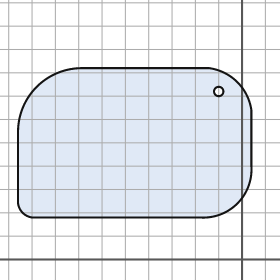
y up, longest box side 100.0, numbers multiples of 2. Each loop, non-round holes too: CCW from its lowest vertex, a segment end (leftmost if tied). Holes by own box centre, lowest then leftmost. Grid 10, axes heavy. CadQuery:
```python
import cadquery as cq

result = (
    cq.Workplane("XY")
    .moveTo(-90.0, 18.0)
    .lineTo(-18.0, 18.0)
    .threePointArc((-2.0, 24.0), (4.0, 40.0))
    .lineTo(4.0, 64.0)
    .threePointArc((-2.0, 76.0), (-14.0, 82.0))
    .lineTo(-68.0, 82.0)
    .threePointArc((-88.0, 74.0), (-96.0, 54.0))
    .lineTo(-96.0, 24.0)
    .threePointArc((-94.0, 20.0), (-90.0, 18.0))
    .close()
    .moveTo(-10.0, 72.0)
    .circle(2.0)
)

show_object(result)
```